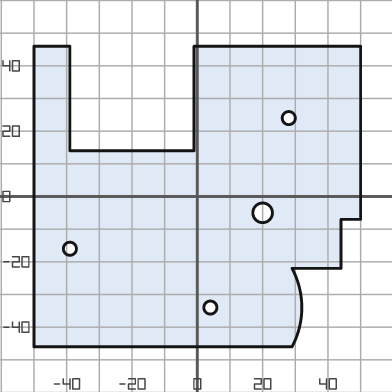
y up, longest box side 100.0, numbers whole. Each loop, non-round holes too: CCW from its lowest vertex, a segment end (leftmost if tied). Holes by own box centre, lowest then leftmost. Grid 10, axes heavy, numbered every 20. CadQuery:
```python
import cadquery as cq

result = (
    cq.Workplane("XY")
    .moveTo(-50.0, -46.0)
    .lineTo(29.0, -46.0)
    .threePointArc((32.0, -34.0), (29.0, -22.0))
    .lineTo(44.0, -22.0)
    .lineTo(44.0, -7.0)
    .lineTo(50.0, -7.0)
    .lineTo(50.0, 46.0)
    .lineTo(-1.0, 46.0)
    .lineTo(-1.0, 14.0)
    .lineTo(-39.0, 14.0)
    .lineTo(-39.0, 46.0)
    .lineTo(-50.0, 46.0)
    .close()
    .moveTo(4.0, -34.0)
    .circle(2.0)
    .moveTo(-39.0, -16.0)
    .circle(2.0)
    .moveTo(20.0, -5.0)
    .circle(3.0)
    .moveTo(28.0, 24.0)
    .circle(2.0)
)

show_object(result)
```